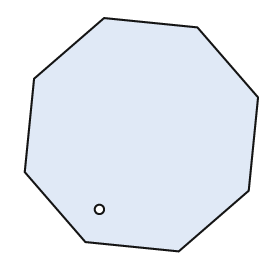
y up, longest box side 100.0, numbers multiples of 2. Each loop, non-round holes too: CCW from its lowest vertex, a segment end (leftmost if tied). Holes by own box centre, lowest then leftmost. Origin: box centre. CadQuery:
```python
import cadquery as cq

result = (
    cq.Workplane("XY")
    .moveTo(16.0, -50.0)
    .lineTo(46.0, -24.0)
    .lineTo(50.0, 16.0)
    .lineTo(24.0, 46.0)
    .lineTo(-16.0, 50.0)
    .lineTo(-46.0, 24.0)
    .lineTo(-50.0, -16.0)
    .lineTo(-24.0, -46.0)
    .close()
    .moveTo(-18.0, -32.0)
    .circle(2.0)
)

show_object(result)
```